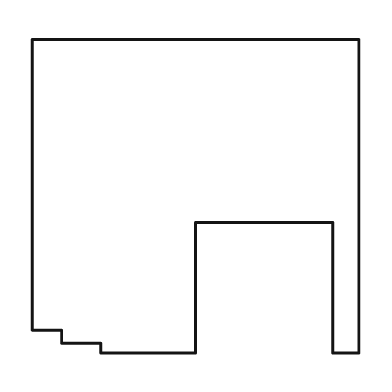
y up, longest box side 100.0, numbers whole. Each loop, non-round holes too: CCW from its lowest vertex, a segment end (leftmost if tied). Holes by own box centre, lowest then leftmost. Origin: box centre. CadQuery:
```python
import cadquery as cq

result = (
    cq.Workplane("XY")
    .moveTo(-29.0, -48.0)
    .lineTo(0.0, -48.0)
    .lineTo(0.0, -8.0)
    .lineTo(42.0, -8.0)
    .lineTo(42.0, -48.0)
    .lineTo(50.0, -48.0)
    .lineTo(50.0, 48.0)
    .lineTo(-50.0, 48.0)
    .lineTo(-50.0, -41.0)
    .lineTo(-41.0, -41.0)
    .lineTo(-41.0, -45.0)
    .lineTo(-29.0, -45.0)
    .close()
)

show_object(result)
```